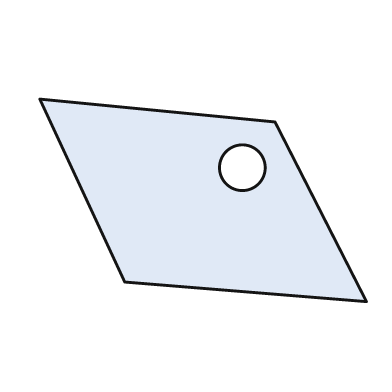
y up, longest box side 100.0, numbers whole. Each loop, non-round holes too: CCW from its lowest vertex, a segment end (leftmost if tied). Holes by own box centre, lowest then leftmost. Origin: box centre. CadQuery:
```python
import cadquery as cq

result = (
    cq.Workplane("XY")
    .moveTo(50.0, -31.0)
    .lineTo(22.0, 24.0)
    .lineTo(-50.0, 31.0)
    .lineTo(-24.0, -25.0)
    .close()
    .moveTo(12.0, 10.0)
    .circle(7.0)
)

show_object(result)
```